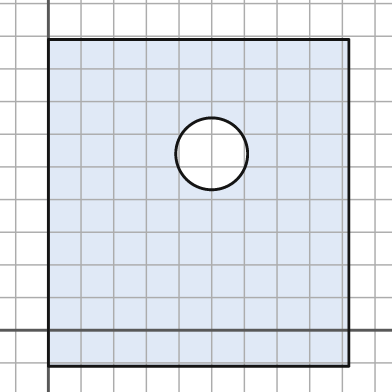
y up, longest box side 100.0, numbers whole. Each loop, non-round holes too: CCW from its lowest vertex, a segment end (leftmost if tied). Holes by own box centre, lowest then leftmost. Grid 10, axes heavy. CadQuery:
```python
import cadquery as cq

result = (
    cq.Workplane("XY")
    .moveTo(0.0, -11.0)
    .lineTo(92.0, -11.0)
    .lineTo(92.0, 89.0)
    .lineTo(0.0, 89.0)
    .close()
    .moveTo(50.0, 54.0)
    .circle(11.0)
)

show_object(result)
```